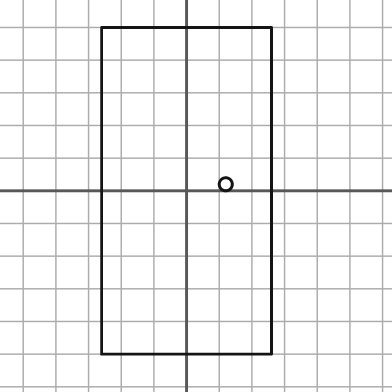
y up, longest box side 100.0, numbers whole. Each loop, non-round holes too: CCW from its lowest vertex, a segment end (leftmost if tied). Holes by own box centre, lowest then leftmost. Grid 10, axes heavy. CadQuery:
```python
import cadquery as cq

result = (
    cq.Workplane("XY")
    .moveTo(-26.0, -50.0)
    .lineTo(26.0, -50.0)
    .lineTo(26.0, 50.0)
    .lineTo(-26.0, 50.0)
    .close()
    .moveTo(12.0, 2.0)
    .circle(2.0)
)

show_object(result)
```